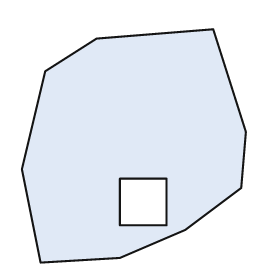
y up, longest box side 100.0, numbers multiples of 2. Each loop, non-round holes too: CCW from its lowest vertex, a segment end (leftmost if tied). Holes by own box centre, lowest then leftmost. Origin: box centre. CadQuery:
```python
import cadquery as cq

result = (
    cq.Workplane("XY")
    .moveTo(-40.0, -50.0)
    .lineTo(-6.0, -48.0)
    .lineTo(22.0, -36.0)
    .lineTo(46.0, -18.0)
    .lineTo(48.0, 6.0)
    .lineTo(34.0, 50.0)
    .lineTo(-16.0, 46.0)
    .lineTo(-38.0, 32.0)
    .lineTo(-48.0, -10.0)
    .close()
    .moveTo(-6.0, -34.0)
    .lineTo(14.0, -34.0)
    .lineTo(14.0, -14.0)
    .lineTo(-6.0, -14.0)
    .close()
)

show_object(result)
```